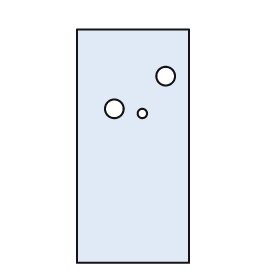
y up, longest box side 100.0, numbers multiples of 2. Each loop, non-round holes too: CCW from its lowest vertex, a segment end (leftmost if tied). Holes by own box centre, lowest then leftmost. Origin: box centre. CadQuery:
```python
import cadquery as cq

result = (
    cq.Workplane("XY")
    .moveTo(-24.0, -50.0)
    .lineTo(24.0, -50.0)
    .lineTo(24.0, 50.0)
    .lineTo(-24.0, 50.0)
    .close()
    .moveTo(4.0, 14.0)
    .circle(2.0)
    .moveTo(-8.0, 16.0)
    .circle(4.0)
    .moveTo(14.0, 30.0)
    .circle(4.0)
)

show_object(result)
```